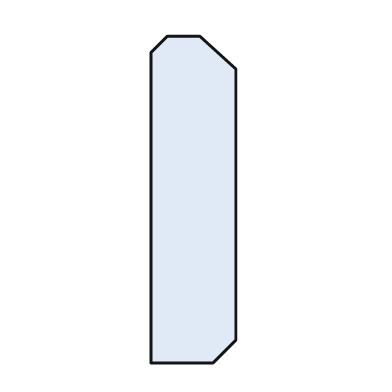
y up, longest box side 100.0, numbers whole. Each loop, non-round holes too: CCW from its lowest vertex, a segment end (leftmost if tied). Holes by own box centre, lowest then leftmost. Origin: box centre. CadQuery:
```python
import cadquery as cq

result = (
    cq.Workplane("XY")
    .moveTo(-13.0, -50.0)
    .lineTo(6.0, -50.0)
    .lineTo(13.0, -43.0)
    .lineTo(13.0, 40.0)
    .lineTo(2.0, 50.0)
    .lineTo(-8.0, 50.0)
    .lineTo(-13.0, 45.0)
    .close()
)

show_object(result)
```